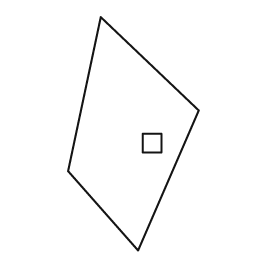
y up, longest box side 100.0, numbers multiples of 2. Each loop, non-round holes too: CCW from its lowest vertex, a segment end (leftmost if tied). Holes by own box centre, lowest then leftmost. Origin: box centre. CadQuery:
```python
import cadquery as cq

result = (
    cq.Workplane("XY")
    .moveTo(2.0, -50.0)
    .lineTo(28.0, 10.0)
    .lineTo(-14.0, 50.0)
    .lineTo(-28.0, -16.0)
    .close()
    .moveTo(4.0, -8.0)
    .lineTo(12.0, -8.0)
    .lineTo(12.0, 0.0)
    .lineTo(4.0, 0.0)
    .close()
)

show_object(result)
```